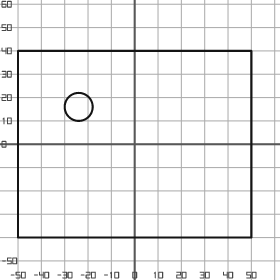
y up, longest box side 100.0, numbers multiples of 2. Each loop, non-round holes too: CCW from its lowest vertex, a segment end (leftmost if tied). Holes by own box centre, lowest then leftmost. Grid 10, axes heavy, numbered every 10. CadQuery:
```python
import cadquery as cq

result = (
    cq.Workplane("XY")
    .moveTo(-50.0, -40.0)
    .lineTo(50.0, -40.0)
    .lineTo(50.0, 40.0)
    .lineTo(-50.0, 40.0)
    .close()
    .moveTo(-24.0, 16.0)
    .circle(6.0)
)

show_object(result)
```